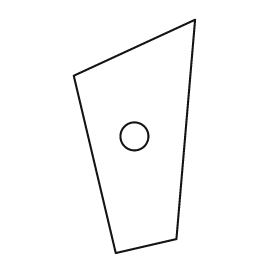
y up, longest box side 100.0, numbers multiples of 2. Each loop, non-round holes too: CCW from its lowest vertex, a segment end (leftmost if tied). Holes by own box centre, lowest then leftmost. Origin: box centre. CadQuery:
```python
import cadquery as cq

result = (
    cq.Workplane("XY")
    .moveTo(-8.0, -50.0)
    .lineTo(18.0, -44.0)
    .lineTo(26.0, 50.0)
    .lineTo(-26.0, 26.0)
    .close()
    .moveTo(0.0, 0.0)
    .circle(6.0)
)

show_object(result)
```